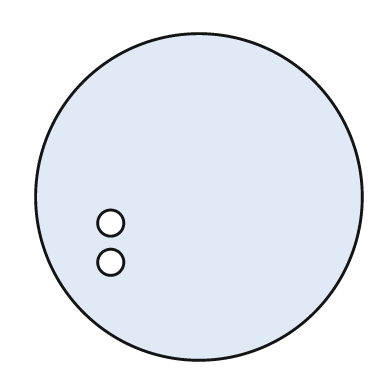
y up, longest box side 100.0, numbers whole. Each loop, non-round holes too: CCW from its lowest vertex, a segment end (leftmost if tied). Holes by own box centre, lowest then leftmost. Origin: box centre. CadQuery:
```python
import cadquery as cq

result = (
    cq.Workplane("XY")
    .moveTo(0.0, 0.0)
    .circle(50.0)
    .moveTo(-27.0, -20.0)
    .circle(4.0)
    .moveTo(-27.0, -8.0)
    .circle(4.0)
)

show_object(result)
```